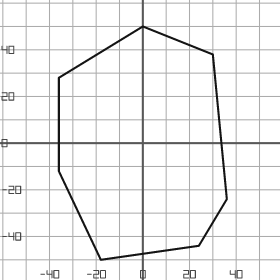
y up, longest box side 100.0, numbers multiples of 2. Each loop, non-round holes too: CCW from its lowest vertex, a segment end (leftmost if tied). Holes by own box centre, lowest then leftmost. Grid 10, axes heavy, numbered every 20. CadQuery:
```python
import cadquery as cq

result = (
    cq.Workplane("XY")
    .moveTo(-18.0, -50.0)
    .lineTo(24.0, -44.0)
    .lineTo(36.0, -24.0)
    .lineTo(30.0, 38.0)
    .lineTo(0.0, 50.0)
    .lineTo(-36.0, 28.0)
    .lineTo(-36.0, -12.0)
    .close()
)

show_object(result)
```